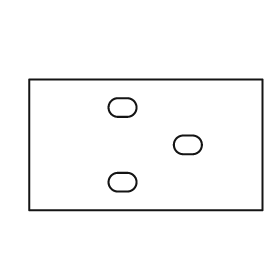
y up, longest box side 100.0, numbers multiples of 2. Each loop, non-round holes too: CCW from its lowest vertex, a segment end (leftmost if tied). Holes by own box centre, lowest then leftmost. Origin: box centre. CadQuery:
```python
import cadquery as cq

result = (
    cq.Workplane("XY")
    .moveTo(-50.0, -28.0)
    .lineTo(50.0, -28.0)
    .lineTo(50.0, 28.0)
    .lineTo(-50.0, 28.0)
    .close()
    .moveTo(-12.0, -20.0)
    .lineTo(-8.0, -20.0)
    .threePointArc((-4.0, -16.0), (-8.0, -12.0))
    .lineTo(-12.0, -12.0)
    .threePointArc((-16.0, -16.0), (-12.0, -20.0))
    .close()
    .moveTo(16.0, -4.0)
    .lineTo(20.0, -4.0)
    .threePointArc((24.0, 0.0), (20.0, 4.0))
    .lineTo(16.0, 4.0)
    .threePointArc((12.0, 0.0), (16.0, -4.0))
    .close()
    .moveTo(-12.0, 12.0)
    .lineTo(-8.0, 12.0)
    .threePointArc((-4.0, 16.0), (-8.0, 20.0))
    .lineTo(-12.0, 20.0)
    .threePointArc((-16.0, 16.0), (-12.0, 12.0))
    .close()
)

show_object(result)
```